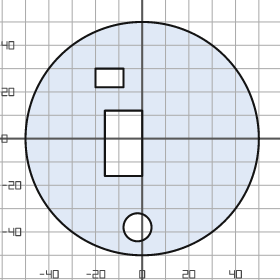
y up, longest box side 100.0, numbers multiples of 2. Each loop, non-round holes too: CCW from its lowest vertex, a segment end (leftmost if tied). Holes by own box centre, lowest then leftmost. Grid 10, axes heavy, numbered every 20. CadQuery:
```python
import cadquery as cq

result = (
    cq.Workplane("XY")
    .moveTo(0.0, 0.0)
    .circle(50.0)
    .moveTo(-2.0, -38.0)
    .circle(6.0)
    .moveTo(-16.0, -16.0)
    .lineTo(0.0, -16.0)
    .lineTo(0.0, 12.0)
    .lineTo(-16.0, 12.0)
    .close()
    .moveTo(-20.0, 22.0)
    .lineTo(-8.0, 22.0)
    .lineTo(-8.0, 30.0)
    .lineTo(-20.0, 30.0)
    .close()
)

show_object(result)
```